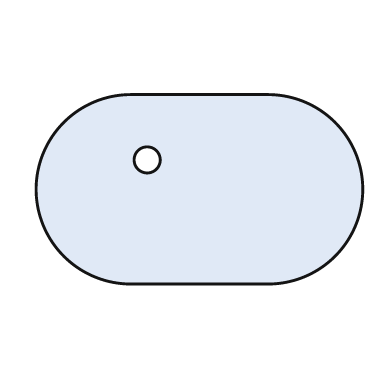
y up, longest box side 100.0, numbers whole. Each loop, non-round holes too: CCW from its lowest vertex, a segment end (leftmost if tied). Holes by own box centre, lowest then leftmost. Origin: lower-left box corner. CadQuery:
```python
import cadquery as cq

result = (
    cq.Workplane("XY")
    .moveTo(29.0, 0.0)
    .lineTo(71.0, 0.0)
    .threePointArc((100.0, 29.0), (71.0, 58.0))
    .lineTo(29.0, 58.0)
    .threePointArc((0.0, 29.0), (29.0, 0.0))
    .close()
    .moveTo(34.0, 38.0)
    .circle(4.0)
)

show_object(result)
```